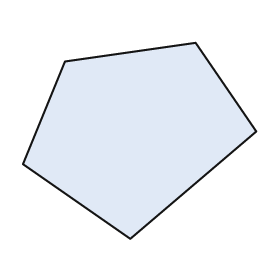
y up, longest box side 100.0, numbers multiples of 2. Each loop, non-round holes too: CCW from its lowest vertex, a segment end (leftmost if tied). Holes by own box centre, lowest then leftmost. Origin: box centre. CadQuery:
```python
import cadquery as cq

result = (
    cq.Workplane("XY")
    .moveTo(-4.0, -42.0)
    .lineTo(50.0, 4.0)
    .lineTo(24.0, 42.0)
    .lineTo(-32.0, 34.0)
    .lineTo(-50.0, -10.0)
    .close()
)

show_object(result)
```